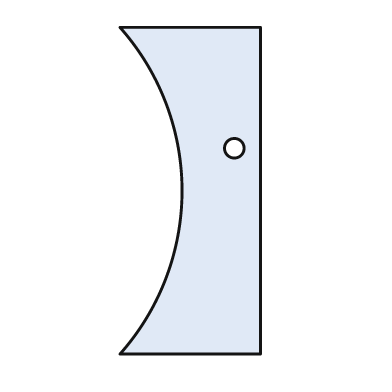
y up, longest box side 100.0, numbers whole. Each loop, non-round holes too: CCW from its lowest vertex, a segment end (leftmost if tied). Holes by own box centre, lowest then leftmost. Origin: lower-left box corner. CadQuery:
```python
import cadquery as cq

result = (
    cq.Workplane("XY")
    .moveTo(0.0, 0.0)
    .lineTo(43.0, 0.0)
    .lineTo(43.0, 100.0)
    .lineTo(0.0, 100.0)
    .threePointArc((19.0, 50.0), (0.0, 0.0))
    .close()
    .moveTo(35.0, 63.0)
    .circle(3.0)
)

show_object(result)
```